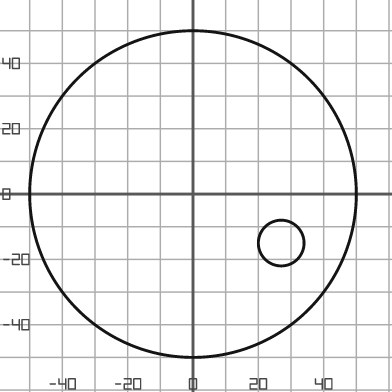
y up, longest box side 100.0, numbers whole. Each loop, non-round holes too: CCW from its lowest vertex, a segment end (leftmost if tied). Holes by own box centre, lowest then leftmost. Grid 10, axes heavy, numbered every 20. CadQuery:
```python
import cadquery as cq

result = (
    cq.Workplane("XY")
    .moveTo(0.0, 0.0)
    .circle(50.0)
    .moveTo(27.0, -15.0)
    .circle(7.0)
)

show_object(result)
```